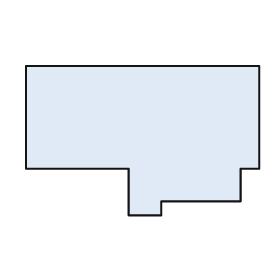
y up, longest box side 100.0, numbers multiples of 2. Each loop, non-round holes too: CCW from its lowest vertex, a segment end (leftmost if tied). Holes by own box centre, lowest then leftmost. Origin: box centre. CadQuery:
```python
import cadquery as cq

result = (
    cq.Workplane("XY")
    .moveTo(-6.0, -32.0)
    .lineTo(8.0, -32.0)
    .lineTo(8.0, -26.0)
    .lineTo(42.0, -26.0)
    .lineTo(42.0, -12.0)
    .lineTo(50.0, -12.0)
    .lineTo(50.0, 32.0)
    .lineTo(-50.0, 32.0)
    .lineTo(-50.0, -12.0)
    .lineTo(-6.0, -12.0)
    .close()
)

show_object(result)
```